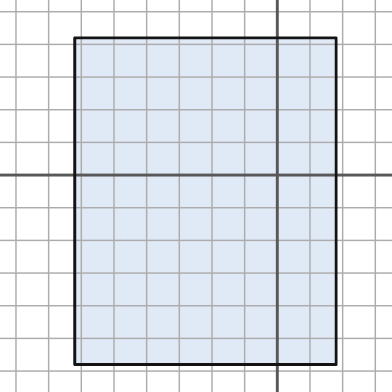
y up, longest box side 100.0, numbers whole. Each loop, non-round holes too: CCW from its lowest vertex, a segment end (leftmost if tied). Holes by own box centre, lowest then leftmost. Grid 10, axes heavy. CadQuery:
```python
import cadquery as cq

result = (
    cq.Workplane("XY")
    .moveTo(-62.0, -58.0)
    .lineTo(18.0, -58.0)
    .lineTo(18.0, 42.0)
    .lineTo(-62.0, 42.0)
    .close()
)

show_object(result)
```